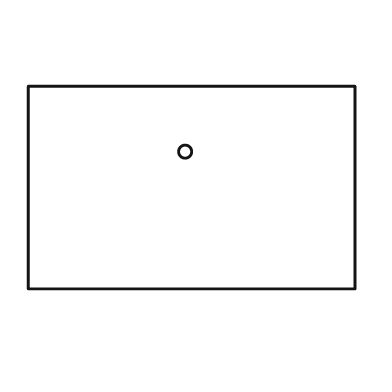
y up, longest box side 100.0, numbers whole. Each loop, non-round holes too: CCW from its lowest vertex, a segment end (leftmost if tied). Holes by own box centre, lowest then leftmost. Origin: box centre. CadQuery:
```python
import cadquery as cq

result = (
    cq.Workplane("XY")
    .moveTo(-50.0, -31.0)
    .lineTo(50.0, -31.0)
    .lineTo(50.0, 31.0)
    .lineTo(-50.0, 31.0)
    .close()
    .moveTo(-2.0, 11.0)
    .circle(2.0)
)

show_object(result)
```